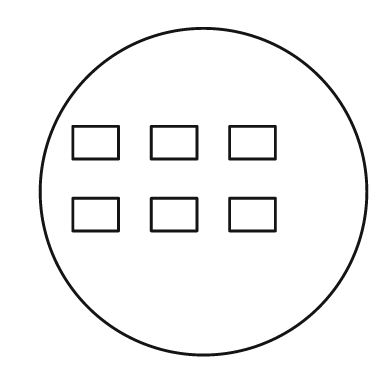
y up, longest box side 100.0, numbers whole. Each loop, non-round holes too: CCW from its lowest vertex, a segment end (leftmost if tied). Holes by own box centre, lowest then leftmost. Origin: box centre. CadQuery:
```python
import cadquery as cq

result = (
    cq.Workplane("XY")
    .moveTo(0.0, 0.0)
    .circle(50.0)
    .moveTo(-40.0, -12.0)
    .lineTo(-26.0, -12.0)
    .lineTo(-26.0, -2.0)
    .lineTo(-40.0, -2.0)
    .close()
    .moveTo(-16.0, -12.0)
    .lineTo(-2.0, -12.0)
    .lineTo(-2.0, -2.0)
    .lineTo(-16.0, -2.0)
    .close()
    .moveTo(8.0, -12.0)
    .lineTo(22.0, -12.0)
    .lineTo(22.0, -2.0)
    .lineTo(8.0, -2.0)
    .close()
    .moveTo(-40.0, 10.0)
    .lineTo(-26.0, 10.0)
    .lineTo(-26.0, 20.0)
    .lineTo(-40.0, 20.0)
    .close()
    .moveTo(-16.0, 10.0)
    .lineTo(-2.0, 10.0)
    .lineTo(-2.0, 20.0)
    .lineTo(-16.0, 20.0)
    .close()
    .moveTo(8.0, 10.0)
    .lineTo(22.0, 10.0)
    .lineTo(22.0, 20.0)
    .lineTo(8.0, 20.0)
    .close()
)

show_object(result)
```